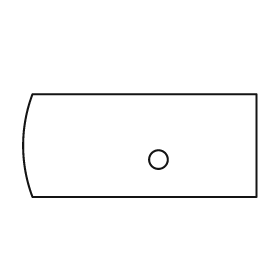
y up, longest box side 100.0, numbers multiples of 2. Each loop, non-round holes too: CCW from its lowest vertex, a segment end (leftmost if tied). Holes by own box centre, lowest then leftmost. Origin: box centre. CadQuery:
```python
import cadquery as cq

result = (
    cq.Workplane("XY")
    .moveTo(-46.0, -22.0)
    .lineTo(50.0, -22.0)
    .lineTo(50.0, 22.0)
    .lineTo(-46.0, 22.0)
    .threePointArc((-50.0, 0.0), (-46.0, -22.0))
    .close()
    .moveTo(8.0, -6.0)
    .circle(4.0)
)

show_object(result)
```